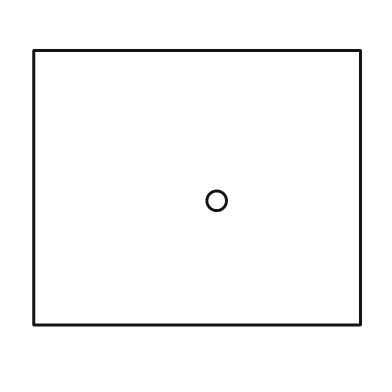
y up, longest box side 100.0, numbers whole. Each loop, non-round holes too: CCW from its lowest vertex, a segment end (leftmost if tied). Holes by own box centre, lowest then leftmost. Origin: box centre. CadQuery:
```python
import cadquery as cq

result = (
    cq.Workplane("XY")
    .moveTo(-50.0, -42.0)
    .lineTo(50.0, -42.0)
    .lineTo(50.0, 42.0)
    .lineTo(-50.0, 42.0)
    .close()
    .moveTo(6.0, -4.0)
    .circle(3.0)
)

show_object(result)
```